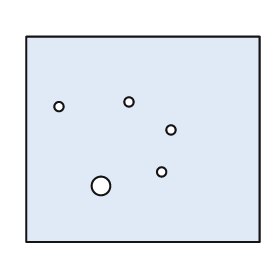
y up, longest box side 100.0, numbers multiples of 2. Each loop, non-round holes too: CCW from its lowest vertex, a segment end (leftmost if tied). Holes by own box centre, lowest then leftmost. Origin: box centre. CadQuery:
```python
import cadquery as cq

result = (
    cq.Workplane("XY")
    .moveTo(-50.0, -44.0)
    .lineTo(50.0, -44.0)
    .lineTo(50.0, 44.0)
    .lineTo(-50.0, 44.0)
    .close()
    .moveTo(-18.0, -20.0)
    .circle(4.0)
    .moveTo(8.0, -14.0)
    .circle(2.0)
    .moveTo(12.0, 4.0)
    .circle(2.0)
    .moveTo(-36.0, 14.0)
    .circle(2.0)
    .moveTo(-6.0, 16.0)
    .circle(2.0)
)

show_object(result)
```